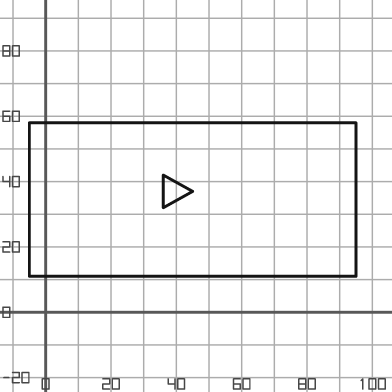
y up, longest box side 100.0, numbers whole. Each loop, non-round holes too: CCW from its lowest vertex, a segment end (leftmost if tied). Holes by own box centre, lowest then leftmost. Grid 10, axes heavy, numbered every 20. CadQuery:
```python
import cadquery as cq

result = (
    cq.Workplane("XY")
    .moveTo(-5.0, 11.0)
    .lineTo(95.0, 11.0)
    .lineTo(95.0, 58.0)
    .lineTo(-5.0, 58.0)
    .close()
    .moveTo(36.0, 32.0)
    .lineTo(45.0, 37.0)
    .lineTo(36.0, 42.0)
    .close()
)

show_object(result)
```